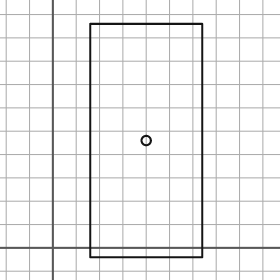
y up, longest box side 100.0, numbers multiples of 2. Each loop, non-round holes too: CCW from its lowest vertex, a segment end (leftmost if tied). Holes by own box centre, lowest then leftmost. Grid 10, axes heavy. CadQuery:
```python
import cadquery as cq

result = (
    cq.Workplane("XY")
    .moveTo(16.0, -4.0)
    .lineTo(64.0, -4.0)
    .lineTo(64.0, 96.0)
    .lineTo(16.0, 96.0)
    .close()
    .moveTo(40.0, 46.0)
    .circle(2.0)
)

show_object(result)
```